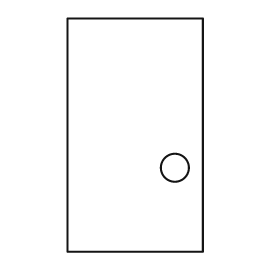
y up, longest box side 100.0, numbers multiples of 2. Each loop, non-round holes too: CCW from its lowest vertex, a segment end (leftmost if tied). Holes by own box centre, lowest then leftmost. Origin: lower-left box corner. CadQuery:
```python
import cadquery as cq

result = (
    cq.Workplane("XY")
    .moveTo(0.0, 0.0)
    .lineTo(58.0, 0.0)
    .lineTo(58.0, 100.0)
    .lineTo(0.0, 100.0)
    .close()
    .moveTo(46.0, 36.0)
    .circle(6.0)
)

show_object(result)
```